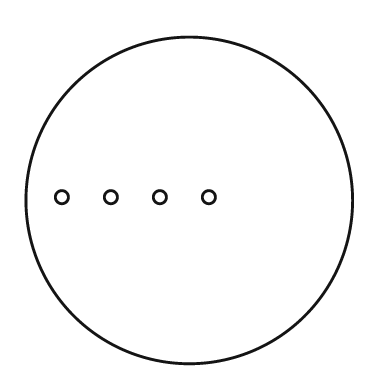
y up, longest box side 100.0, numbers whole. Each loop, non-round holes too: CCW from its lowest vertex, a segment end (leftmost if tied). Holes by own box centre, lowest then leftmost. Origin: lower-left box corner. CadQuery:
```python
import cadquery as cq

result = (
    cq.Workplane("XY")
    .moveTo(50.0, 50.0)
    .circle(50.0)
    .moveTo(11.0, 51.0)
    .circle(2.0)
    .moveTo(26.0, 51.0)
    .circle(2.0)
    .moveTo(41.0, 51.0)
    .circle(2.0)
    .moveTo(56.0, 51.0)
    .circle(2.0)
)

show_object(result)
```